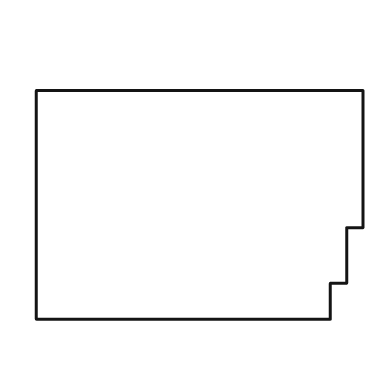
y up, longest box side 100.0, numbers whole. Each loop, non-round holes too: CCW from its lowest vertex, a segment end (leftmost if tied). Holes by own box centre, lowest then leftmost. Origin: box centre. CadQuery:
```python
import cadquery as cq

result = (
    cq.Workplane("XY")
    .moveTo(-50.0, -35.0)
    .lineTo(40.0, -35.0)
    .lineTo(40.0, -24.0)
    .lineTo(45.0, -24.0)
    .lineTo(45.0, -7.0)
    .lineTo(50.0, -7.0)
    .lineTo(50.0, 35.0)
    .lineTo(-50.0, 35.0)
    .close()
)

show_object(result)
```